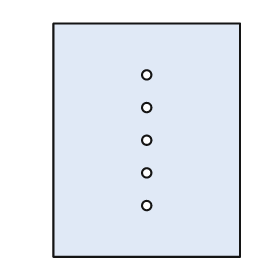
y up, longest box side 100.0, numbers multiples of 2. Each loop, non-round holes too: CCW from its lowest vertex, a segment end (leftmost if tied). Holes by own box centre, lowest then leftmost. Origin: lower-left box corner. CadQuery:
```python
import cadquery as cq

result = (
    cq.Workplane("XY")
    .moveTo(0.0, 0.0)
    .lineTo(80.0, 0.0)
    .lineTo(80.0, 100.0)
    .lineTo(0.0, 100.0)
    .close()
    .moveTo(40.0, 22.0)
    .circle(2.0)
    .moveTo(40.0, 36.0)
    .circle(2.0)
    .moveTo(40.0, 50.0)
    .circle(2.0)
    .moveTo(40.0, 64.0)
    .circle(2.0)
    .moveTo(40.0, 78.0)
    .circle(2.0)
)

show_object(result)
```